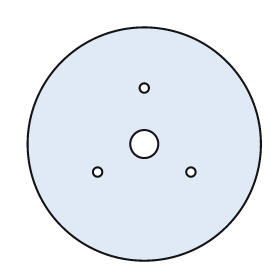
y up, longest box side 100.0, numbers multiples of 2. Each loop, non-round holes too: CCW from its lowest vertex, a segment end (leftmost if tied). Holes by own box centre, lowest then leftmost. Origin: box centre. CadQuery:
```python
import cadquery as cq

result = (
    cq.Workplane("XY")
    .moveTo(0.0, 0.0)
    .circle(50.0)
    .moveTo(-20.0, -12.0)
    .circle(2.0)
    .moveTo(20.0, -12.0)
    .circle(2.0)
    .moveTo(0.0, 0.0)
    .circle(6.0)
    .moveTo(0.0, 24.0)
    .circle(2.0)
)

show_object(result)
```